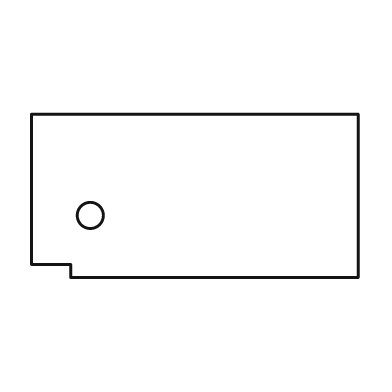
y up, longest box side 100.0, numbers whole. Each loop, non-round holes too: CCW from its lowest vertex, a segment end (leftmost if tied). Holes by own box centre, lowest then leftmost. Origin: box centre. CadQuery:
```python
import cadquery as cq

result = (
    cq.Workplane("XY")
    .moveTo(-38.0, -25.0)
    .lineTo(50.0, -25.0)
    .lineTo(50.0, 25.0)
    .lineTo(-50.0, 25.0)
    .lineTo(-50.0, -21.0)
    .lineTo(-38.0, -21.0)
    .close()
    .moveTo(-32.0, -6.0)
    .circle(4.0)
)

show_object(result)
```